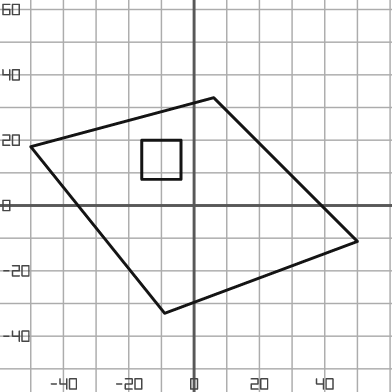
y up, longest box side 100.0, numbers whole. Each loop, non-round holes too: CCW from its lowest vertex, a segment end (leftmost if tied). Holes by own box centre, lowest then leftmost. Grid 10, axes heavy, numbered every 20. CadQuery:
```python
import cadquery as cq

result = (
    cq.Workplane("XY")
    .moveTo(-9.0, -33.0)
    .lineTo(50.0, -11.0)
    .lineTo(6.0, 33.0)
    .lineTo(-50.0, 18.0)
    .close()
    .moveTo(-16.0, 8.0)
    .lineTo(-4.0, 8.0)
    .lineTo(-4.0, 20.0)
    .lineTo(-16.0, 20.0)
    .close()
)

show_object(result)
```